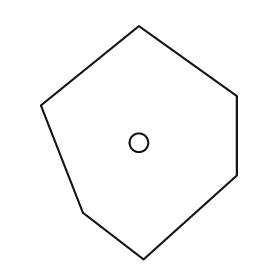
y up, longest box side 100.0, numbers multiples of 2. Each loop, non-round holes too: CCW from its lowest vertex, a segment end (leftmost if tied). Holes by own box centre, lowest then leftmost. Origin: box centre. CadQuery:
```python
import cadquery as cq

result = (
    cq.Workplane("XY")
    .moveTo(2.0, -50.0)
    .lineTo(42.0, -14.0)
    .lineTo(42.0, 20.0)
    .lineTo(0.0, 50.0)
    .lineTo(-42.0, 16.0)
    .lineTo(-24.0, -30.0)
    .close()
    .moveTo(0.0, 0.0)
    .circle(4.0)
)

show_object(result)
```